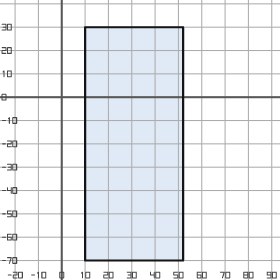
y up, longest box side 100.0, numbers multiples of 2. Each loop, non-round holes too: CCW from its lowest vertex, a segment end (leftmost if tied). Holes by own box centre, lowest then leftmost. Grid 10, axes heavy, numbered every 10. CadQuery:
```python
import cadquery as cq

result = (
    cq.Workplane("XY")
    .moveTo(10.0, -70.0)
    .lineTo(52.0, -70.0)
    .lineTo(52.0, 30.0)
    .lineTo(10.0, 30.0)
    .close()
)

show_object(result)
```